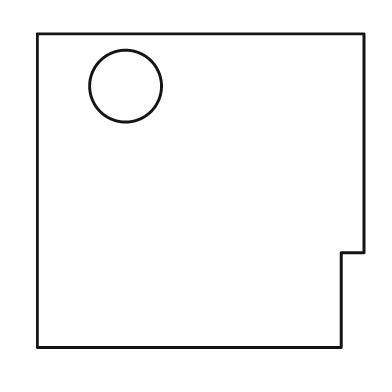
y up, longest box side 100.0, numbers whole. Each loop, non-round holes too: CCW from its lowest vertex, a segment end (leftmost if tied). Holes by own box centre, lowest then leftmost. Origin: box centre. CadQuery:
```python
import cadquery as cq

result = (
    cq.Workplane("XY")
    .moveTo(-50.0, -48.0)
    .lineTo(43.0, -48.0)
    .lineTo(43.0, -19.0)
    .lineTo(50.0, -19.0)
    .lineTo(50.0, 48.0)
    .lineTo(-50.0, 48.0)
    .close()
    .moveTo(-23.0, 32.0)
    .circle(11.0)
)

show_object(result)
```